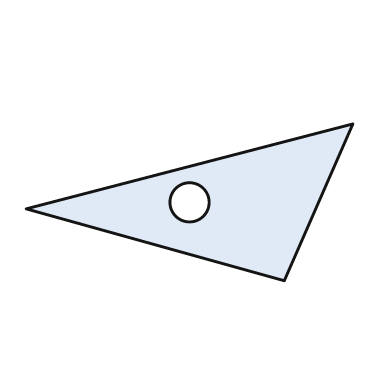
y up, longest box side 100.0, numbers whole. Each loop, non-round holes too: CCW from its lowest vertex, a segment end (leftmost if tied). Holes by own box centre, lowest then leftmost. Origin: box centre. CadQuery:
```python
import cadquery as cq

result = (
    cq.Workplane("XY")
    .moveTo(29.0, -24.0)
    .lineTo(50.0, 24.0)
    .lineTo(-50.0, -2.0)
    .close()
    .moveTo(0.0, 0.0)
    .circle(6.0)
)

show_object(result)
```